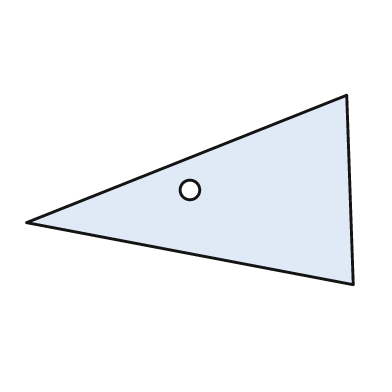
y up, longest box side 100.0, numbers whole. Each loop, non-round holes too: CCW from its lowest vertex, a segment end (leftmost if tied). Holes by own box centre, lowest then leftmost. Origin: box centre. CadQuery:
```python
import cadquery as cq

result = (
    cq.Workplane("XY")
    .moveTo(50.0, -29.0)
    .lineTo(48.0, 29.0)
    .lineTo(-50.0, -10.0)
    .close()
    .moveTo(0.0, 0.0)
    .circle(3.0)
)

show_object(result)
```